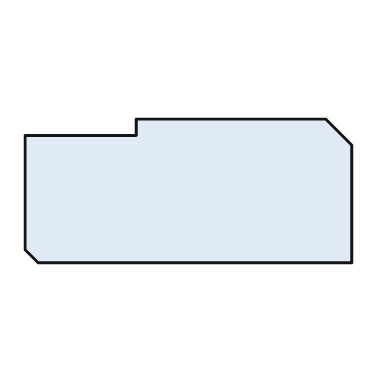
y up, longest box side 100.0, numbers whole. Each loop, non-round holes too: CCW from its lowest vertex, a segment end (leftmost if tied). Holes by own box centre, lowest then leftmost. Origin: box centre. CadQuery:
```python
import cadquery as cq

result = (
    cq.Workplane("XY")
    .moveTo(-46.0, -22.0)
    .lineTo(50.0, -22.0)
    .lineTo(50.0, 14.0)
    .lineTo(42.0, 22.0)
    .lineTo(-16.0, 22.0)
    .lineTo(-16.0, 17.0)
    .lineTo(-50.0, 17.0)
    .lineTo(-50.0, -18.0)
    .close()
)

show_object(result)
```